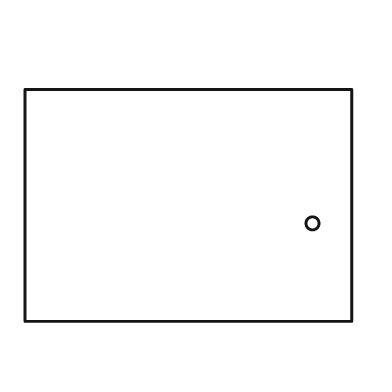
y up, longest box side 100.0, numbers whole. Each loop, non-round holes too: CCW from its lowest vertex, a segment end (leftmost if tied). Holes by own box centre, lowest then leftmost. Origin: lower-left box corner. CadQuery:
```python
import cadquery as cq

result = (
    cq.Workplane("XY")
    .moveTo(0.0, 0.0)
    .lineTo(100.0, 0.0)
    .lineTo(100.0, 71.0)
    .lineTo(0.0, 71.0)
    .close()
    .moveTo(88.0, 30.0)
    .circle(2.0)
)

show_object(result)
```